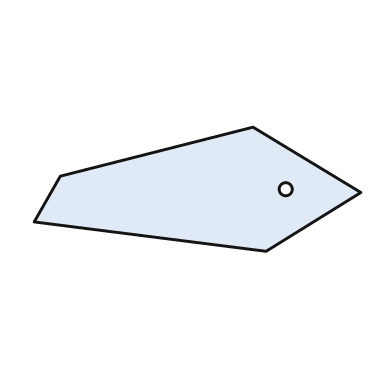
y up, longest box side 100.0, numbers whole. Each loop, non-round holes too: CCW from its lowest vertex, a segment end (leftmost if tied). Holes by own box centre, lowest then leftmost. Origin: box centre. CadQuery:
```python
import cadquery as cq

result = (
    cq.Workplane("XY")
    .moveTo(21.0, -19.0)
    .lineTo(50.0, -1.0)
    .lineTo(17.0, 19.0)
    .lineTo(-42.0, 4.0)
    .lineTo(-50.0, -10.0)
    .close()
    .moveTo(27.0, 0.0)
    .circle(2.0)
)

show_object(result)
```